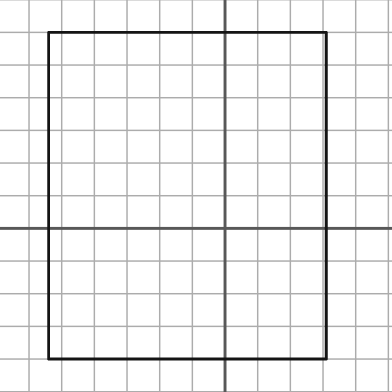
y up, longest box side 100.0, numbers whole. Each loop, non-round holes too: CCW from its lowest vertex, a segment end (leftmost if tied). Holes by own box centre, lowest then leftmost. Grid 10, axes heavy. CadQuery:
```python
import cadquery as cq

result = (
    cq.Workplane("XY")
    .moveTo(-54.0, -40.0)
    .lineTo(31.0, -40.0)
    .lineTo(31.0, 60.0)
    .lineTo(-54.0, 60.0)
    .close()
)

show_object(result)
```